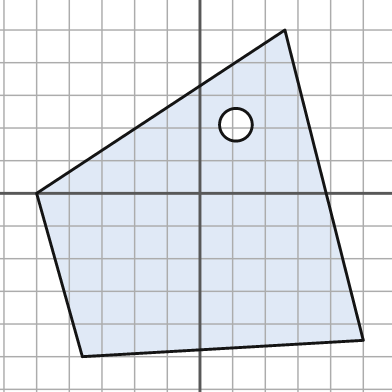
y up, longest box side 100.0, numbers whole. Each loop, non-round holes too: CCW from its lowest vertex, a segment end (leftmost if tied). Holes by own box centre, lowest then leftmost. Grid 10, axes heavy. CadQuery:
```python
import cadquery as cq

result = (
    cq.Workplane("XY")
    .moveTo(-36.0, -50.0)
    .lineTo(50.0, -45.0)
    .lineTo(26.0, 50.0)
    .lineTo(-50.0, 0.0)
    .close()
    .moveTo(11.0, 21.0)
    .circle(5.0)
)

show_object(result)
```